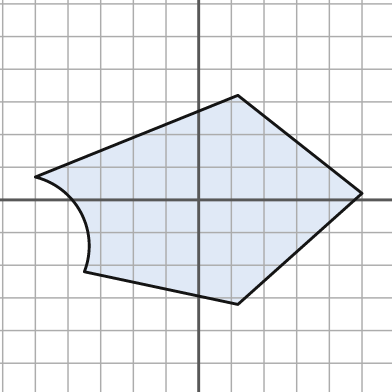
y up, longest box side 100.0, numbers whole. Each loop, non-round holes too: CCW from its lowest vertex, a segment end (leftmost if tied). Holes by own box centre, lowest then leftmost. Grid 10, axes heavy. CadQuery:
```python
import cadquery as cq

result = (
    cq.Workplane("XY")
    .moveTo(12.0, -32.0)
    .lineTo(50.0, 2.0)
    .lineTo(12.0, 32.0)
    .lineTo(-50.0, 7.0)
    .threePointArc((-36.0, -4.0), (-35.0, -22.0))
    .close()
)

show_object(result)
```